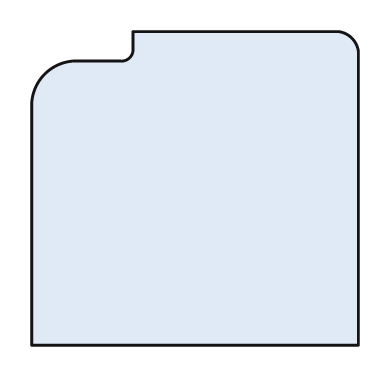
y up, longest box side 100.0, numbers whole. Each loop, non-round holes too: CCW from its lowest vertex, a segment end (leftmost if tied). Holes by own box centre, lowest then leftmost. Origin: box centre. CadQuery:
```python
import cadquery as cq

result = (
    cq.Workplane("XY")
    .moveTo(-50.0, -48.0)
    .lineTo(50.0, -48.0)
    .lineTo(50.0, 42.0)
    .threePointArc((48.0, 46.0), (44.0, 48.0))
    .lineTo(-19.0, 48.0)
    .lineTo(-19.0, 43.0)
    .threePointArc((-20.0, 40.0), (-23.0, 39.0))
    .lineTo(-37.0, 39.0)
    .threePointArc((-46.0, 35.0), (-50.0, 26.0))
    .close()
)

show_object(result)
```